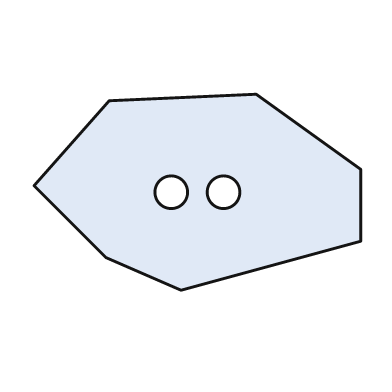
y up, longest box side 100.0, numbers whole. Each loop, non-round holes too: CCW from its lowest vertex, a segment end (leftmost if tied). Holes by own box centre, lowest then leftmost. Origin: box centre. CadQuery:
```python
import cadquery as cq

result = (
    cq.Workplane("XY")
    .moveTo(-5.0, -30.0)
    .lineTo(50.0, -15.0)
    .lineTo(50.0, 7.0)
    .lineTo(18.0, 30.0)
    .lineTo(-27.0, 28.0)
    .lineTo(-50.0, 2.0)
    .lineTo(-28.0, -20.0)
    .close()
    .moveTo(-8.0, 0.0)
    .circle(5.0)
    .moveTo(8.0, 0.0)
    .circle(5.0)
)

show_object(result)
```